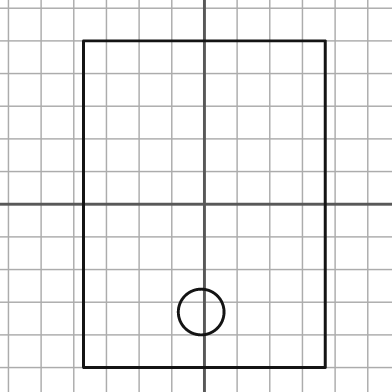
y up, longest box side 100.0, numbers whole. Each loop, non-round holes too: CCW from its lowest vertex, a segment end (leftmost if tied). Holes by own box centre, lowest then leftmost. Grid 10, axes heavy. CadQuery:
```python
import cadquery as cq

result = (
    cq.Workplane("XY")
    .moveTo(-37.0, -50.0)
    .lineTo(37.0, -50.0)
    .lineTo(37.0, 50.0)
    .lineTo(-37.0, 50.0)
    .close()
    .moveTo(-1.0, -33.0)
    .circle(7.0)
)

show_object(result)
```